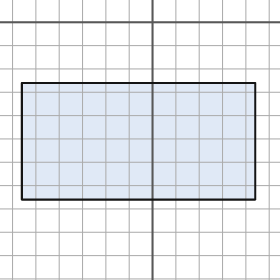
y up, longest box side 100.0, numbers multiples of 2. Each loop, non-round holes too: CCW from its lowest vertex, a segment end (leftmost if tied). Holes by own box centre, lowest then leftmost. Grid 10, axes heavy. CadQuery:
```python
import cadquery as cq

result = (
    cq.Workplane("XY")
    .moveTo(-56.0, -76.0)
    .lineTo(44.0, -76.0)
    .lineTo(44.0, -26.0)
    .lineTo(-56.0, -26.0)
    .close()
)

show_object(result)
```